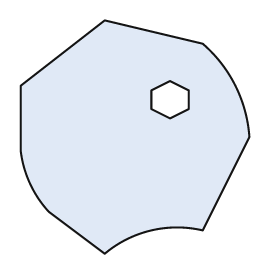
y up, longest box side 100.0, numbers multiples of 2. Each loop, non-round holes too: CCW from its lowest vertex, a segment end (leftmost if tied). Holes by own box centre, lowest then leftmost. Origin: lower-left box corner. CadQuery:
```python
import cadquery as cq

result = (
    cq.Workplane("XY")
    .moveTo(36.0, 0.0)
    .threePointArc((56.0, 10.0), (78.0, 10.0))
    .lineTo(98.0, 50.0)
    .threePointArc((92.0, 72.0), (78.0, 90.0))
    .lineTo(36.0, 100.0)
    .lineTo(0.0, 72.0)
    .lineTo(0.0, 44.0)
    .threePointArc((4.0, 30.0), (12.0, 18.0))
    .close()
    .moveTo(64.0, 58.0)
    .lineTo(72.0, 62.0)
    .lineTo(72.0, 70.0)
    .lineTo(64.0, 74.0)
    .lineTo(56.0, 70.0)
    .lineTo(56.0, 62.0)
    .close()
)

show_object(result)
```